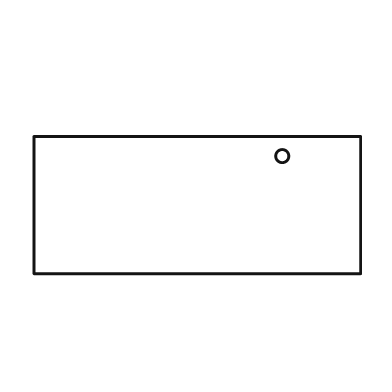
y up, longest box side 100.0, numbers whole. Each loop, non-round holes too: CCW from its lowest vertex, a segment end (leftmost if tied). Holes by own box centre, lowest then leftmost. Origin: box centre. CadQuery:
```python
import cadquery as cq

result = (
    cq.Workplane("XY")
    .moveTo(-50.0, -21.0)
    .lineTo(50.0, -21.0)
    .lineTo(50.0, 21.0)
    .lineTo(-50.0, 21.0)
    .close()
    .moveTo(26.0, 15.0)
    .circle(2.0)
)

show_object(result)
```